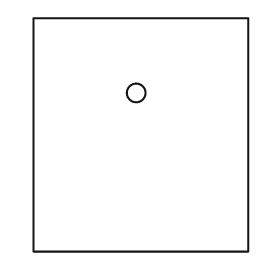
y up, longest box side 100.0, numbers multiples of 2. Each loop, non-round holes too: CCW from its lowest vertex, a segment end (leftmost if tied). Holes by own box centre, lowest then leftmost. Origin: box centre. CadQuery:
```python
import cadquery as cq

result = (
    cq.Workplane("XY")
    .moveTo(-46.0, -50.0)
    .lineTo(46.0, -50.0)
    .lineTo(46.0, 50.0)
    .lineTo(-46.0, 50.0)
    .close()
    .moveTo(-2.0, 18.0)
    .circle(4.0)
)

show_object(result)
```